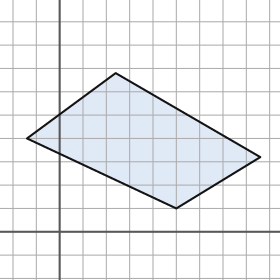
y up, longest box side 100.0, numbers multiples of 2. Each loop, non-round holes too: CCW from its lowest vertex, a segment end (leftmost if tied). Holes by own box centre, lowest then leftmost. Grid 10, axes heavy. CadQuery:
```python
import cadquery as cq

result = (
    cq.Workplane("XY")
    .moveTo(50.0, 10.0)
    .lineTo(86.0, 32.0)
    .lineTo(24.0, 68.0)
    .lineTo(-14.0, 40.0)
    .close()
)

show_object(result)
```